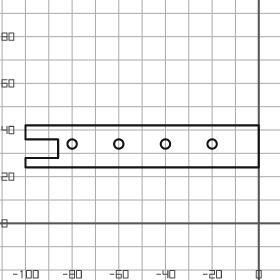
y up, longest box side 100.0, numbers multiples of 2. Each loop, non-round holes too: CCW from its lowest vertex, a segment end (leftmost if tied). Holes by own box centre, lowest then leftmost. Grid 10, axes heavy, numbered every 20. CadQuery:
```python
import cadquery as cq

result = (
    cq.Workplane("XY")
    .moveTo(-100.0, 24.0)
    .lineTo(0.0, 24.0)
    .lineTo(0.0, 42.0)
    .lineTo(-100.0, 42.0)
    .lineTo(-100.0, 36.0)
    .lineTo(-86.0, 36.0)
    .lineTo(-86.0, 28.0)
    .lineTo(-100.0, 28.0)
    .close()
    .moveTo(-80.0, 34.0)
    .circle(2.0)
    .moveTo(-60.0, 34.0)
    .circle(2.0)
    .moveTo(-40.0, 34.0)
    .circle(2.0)
    .moveTo(-20.0, 34.0)
    .circle(2.0)
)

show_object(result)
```